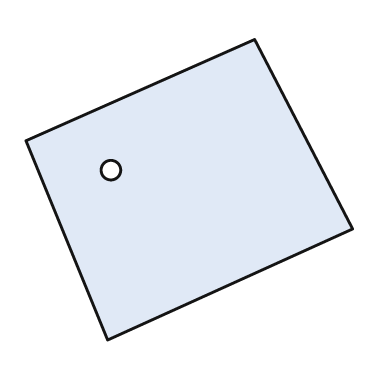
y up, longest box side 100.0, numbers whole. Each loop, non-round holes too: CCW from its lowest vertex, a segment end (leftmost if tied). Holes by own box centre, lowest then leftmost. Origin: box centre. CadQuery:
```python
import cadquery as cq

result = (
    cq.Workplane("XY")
    .moveTo(-25.0, -46.0)
    .lineTo(50.0, -12.0)
    .lineTo(20.0, 46.0)
    .lineTo(-50.0, 15.0)
    .close()
    .moveTo(-24.0, 6.0)
    .circle(3.0)
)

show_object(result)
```